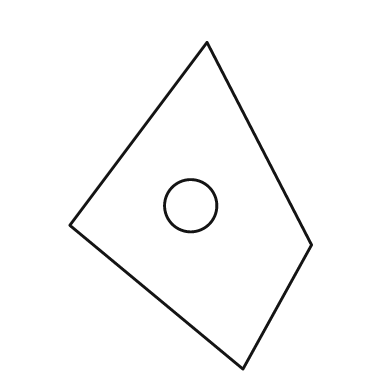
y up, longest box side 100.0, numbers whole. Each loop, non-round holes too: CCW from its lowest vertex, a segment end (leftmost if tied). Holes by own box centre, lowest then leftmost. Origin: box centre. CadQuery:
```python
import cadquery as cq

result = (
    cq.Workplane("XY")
    .moveTo(16.0, -50.0)
    .lineTo(37.0, -12.0)
    .lineTo(5.0, 50.0)
    .lineTo(-37.0, -6.0)
    .close()
    .moveTo(0.0, 0.0)
    .circle(8.0)
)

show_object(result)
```